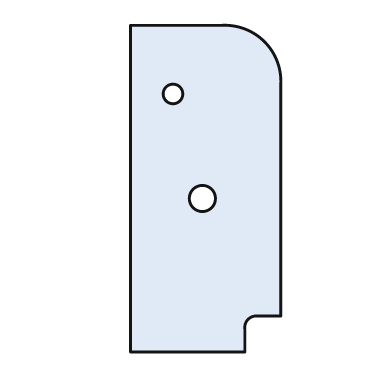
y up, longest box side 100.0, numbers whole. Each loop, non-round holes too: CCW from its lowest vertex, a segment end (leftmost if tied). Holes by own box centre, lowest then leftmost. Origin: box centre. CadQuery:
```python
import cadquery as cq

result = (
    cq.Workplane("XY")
    .moveTo(-23.0, -50.0)
    .lineTo(12.0, -50.0)
    .lineTo(12.0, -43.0)
    .threePointArc((13.0, -40.0), (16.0, -39.0))
    .lineTo(23.0, -39.0)
    .lineTo(23.0, 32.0)
    .threePointArc((18.0, 45.0), (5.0, 50.0))
    .lineTo(-23.0, 50.0)
    .close()
    .moveTo(-1.0, -3.0)
    .circle(4.0)
    .moveTo(-10.0, 29.0)
    .circle(3.0)
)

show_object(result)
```